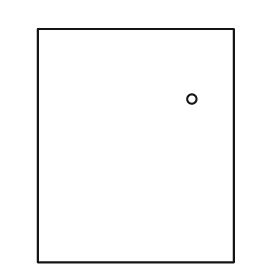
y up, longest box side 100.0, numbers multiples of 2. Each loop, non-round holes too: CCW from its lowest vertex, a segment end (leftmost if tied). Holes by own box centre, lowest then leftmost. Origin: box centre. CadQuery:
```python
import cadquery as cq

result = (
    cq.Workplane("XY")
    .moveTo(-42.0, -50.0)
    .lineTo(42.0, -50.0)
    .lineTo(42.0, 50.0)
    .lineTo(-42.0, 50.0)
    .close()
    .moveTo(24.0, 20.0)
    .circle(2.0)
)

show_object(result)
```